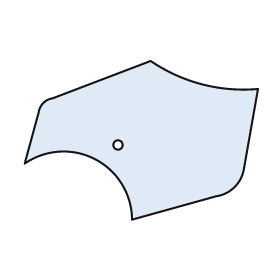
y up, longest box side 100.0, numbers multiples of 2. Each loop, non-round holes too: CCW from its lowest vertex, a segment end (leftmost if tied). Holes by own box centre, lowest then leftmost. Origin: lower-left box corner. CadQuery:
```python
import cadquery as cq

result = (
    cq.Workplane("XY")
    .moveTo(46.0, 0.0)
    .lineTo(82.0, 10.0)
    .threePointArc((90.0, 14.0), (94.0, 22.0))
    .lineTo(100.0, 56.0)
    .threePointArc((76.0, 58.0), (54.0, 68.0))
    .lineTo(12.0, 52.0)
    .threePointArc((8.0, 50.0), (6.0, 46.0))
    .lineTo(0.0, 24.0)
    .threePointArc((30.0, 26.0), (46.0, 0.0))
    .close()
    .moveTo(40.0, 32.0)
    .circle(2.0)
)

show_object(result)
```